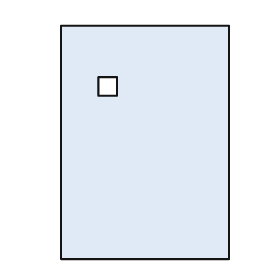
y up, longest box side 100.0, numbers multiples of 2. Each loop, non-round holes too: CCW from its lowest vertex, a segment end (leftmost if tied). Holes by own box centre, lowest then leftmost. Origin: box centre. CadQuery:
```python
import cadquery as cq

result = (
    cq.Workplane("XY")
    .moveTo(-36.0, -50.0)
    .lineTo(36.0, -50.0)
    .lineTo(36.0, 50.0)
    .lineTo(-36.0, 50.0)
    .close()
    .moveTo(-20.0, 20.0)
    .lineTo(-12.0, 20.0)
    .lineTo(-12.0, 28.0)
    .lineTo(-20.0, 28.0)
    .close()
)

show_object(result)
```